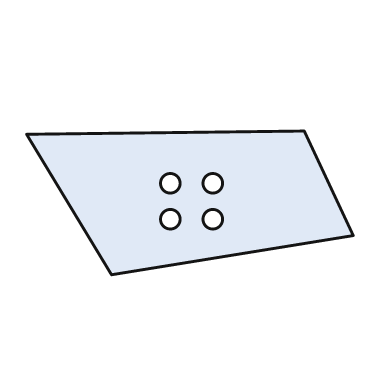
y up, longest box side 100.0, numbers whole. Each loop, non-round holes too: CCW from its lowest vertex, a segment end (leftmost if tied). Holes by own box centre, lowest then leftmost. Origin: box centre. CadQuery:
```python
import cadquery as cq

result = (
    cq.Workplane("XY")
    .moveTo(-24.0, -22.0)
    .lineTo(50.0, -10.0)
    .lineTo(35.0, 22.0)
    .lineTo(-50.0, 21.0)
    .close()
    .moveTo(-6.0, -5.0)
    .circle(3.0)
    .moveTo(7.0, -5.0)
    .circle(3.0)
    .moveTo(-6.0, 6.0)
    .circle(3.0)
    .moveTo(7.0, 6.0)
    .circle(3.0)
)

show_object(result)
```